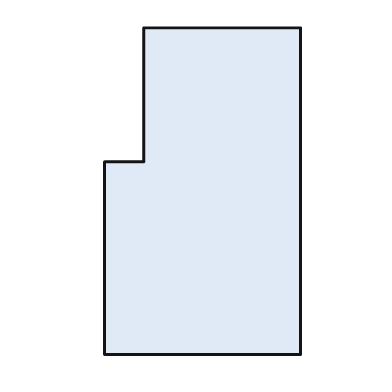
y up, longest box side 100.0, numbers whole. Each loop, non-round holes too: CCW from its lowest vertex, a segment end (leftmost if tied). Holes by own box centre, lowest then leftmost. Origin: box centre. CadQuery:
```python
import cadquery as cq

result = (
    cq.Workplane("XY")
    .moveTo(-30.0, -50.0)
    .lineTo(30.0, -50.0)
    .lineTo(30.0, 50.0)
    .lineTo(-18.0, 50.0)
    .lineTo(-18.0, 9.0)
    .lineTo(-30.0, 9.0)
    .close()
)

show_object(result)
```